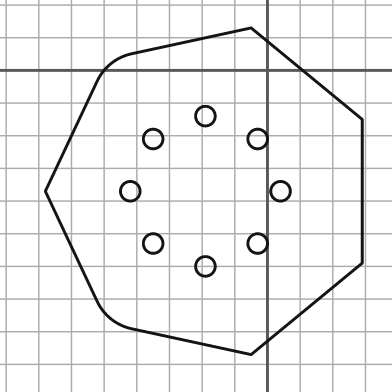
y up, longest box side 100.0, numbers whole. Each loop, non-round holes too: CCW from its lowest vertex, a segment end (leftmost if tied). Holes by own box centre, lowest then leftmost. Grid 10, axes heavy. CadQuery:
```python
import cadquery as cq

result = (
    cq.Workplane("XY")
    .moveTo(-5.0, -87.0)
    .lineTo(29.0, -59.0)
    .lineTo(29.0, -15.0)
    .lineTo(-5.0, 13.0)
    .lineTo(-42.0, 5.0)
    .threePointArc((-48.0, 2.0), (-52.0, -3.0))
    .lineTo(-68.0, -37.0)
    .lineTo(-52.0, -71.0)
    .threePointArc((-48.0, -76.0), (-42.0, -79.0))
    .close()
    .moveTo(-19.0, -60.0)
    .circle(3.0)
    .moveTo(-35.0, -53.0)
    .circle(3.0)
    .moveTo(-3.0, -53.0)
    .circle(3.0)
    .moveTo(-42.0, -37.0)
    .circle(3.0)
    .moveTo(4.0, -37.0)
    .circle(3.0)
    .moveTo(-35.0, -21.0)
    .circle(3.0)
    .moveTo(-3.0, -21.0)
    .circle(3.0)
    .moveTo(-19.0, -14.0)
    .circle(3.0)
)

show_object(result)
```